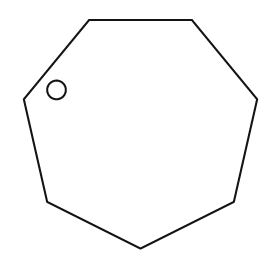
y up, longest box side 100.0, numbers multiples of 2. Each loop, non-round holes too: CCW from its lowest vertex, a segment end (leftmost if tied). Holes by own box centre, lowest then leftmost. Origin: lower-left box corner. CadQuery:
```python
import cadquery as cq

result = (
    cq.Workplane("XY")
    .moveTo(50.0, 0.0)
    .lineTo(90.0, 20.0)
    .lineTo(100.0, 64.0)
    .lineTo(72.0, 98.0)
    .lineTo(28.0, 98.0)
    .lineTo(0.0, 64.0)
    .lineTo(10.0, 20.0)
    .close()
    .moveTo(14.0, 68.0)
    .circle(4.0)
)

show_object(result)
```